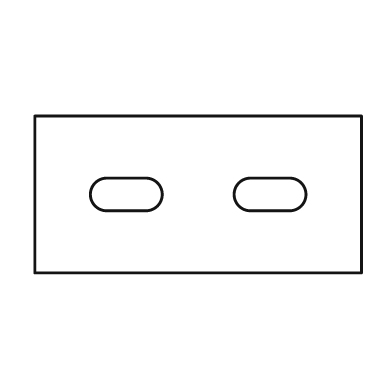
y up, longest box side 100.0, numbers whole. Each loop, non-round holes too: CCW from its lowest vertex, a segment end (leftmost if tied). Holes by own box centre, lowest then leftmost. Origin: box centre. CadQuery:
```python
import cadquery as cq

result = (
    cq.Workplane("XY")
    .moveTo(-50.0, -24.0)
    .lineTo(50.0, -24.0)
    .lineTo(50.0, 24.0)
    .lineTo(-50.0, 24.0)
    .close()
    .moveTo(-28.0, -5.0)
    .lineTo(-16.0, -5.0)
    .threePointArc((-11.0, 0.0), (-16.0, 5.0))
    .lineTo(-28.0, 5.0)
    .threePointArc((-33.0, 0.0), (-28.0, -5.0))
    .close()
    .moveTo(16.0, -5.0)
    .lineTo(28.0, -5.0)
    .threePointArc((33.0, 0.0), (28.0, 5.0))
    .lineTo(16.0, 5.0)
    .threePointArc((11.0, 0.0), (16.0, -5.0))
    .close()
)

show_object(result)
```